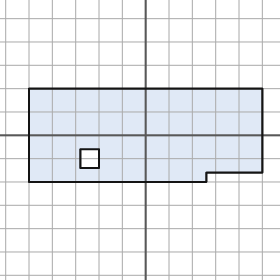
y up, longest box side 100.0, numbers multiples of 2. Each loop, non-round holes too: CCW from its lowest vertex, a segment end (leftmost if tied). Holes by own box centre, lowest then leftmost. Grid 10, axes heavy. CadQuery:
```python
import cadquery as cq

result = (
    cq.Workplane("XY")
    .moveTo(-50.0, -20.0)
    .lineTo(26.0, -20.0)
    .lineTo(26.0, -16.0)
    .lineTo(50.0, -16.0)
    .lineTo(50.0, 20.0)
    .lineTo(-50.0, 20.0)
    .close()
    .moveTo(-28.0, -14.0)
    .lineTo(-20.0, -14.0)
    .lineTo(-20.0, -6.0)
    .lineTo(-28.0, -6.0)
    .close()
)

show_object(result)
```